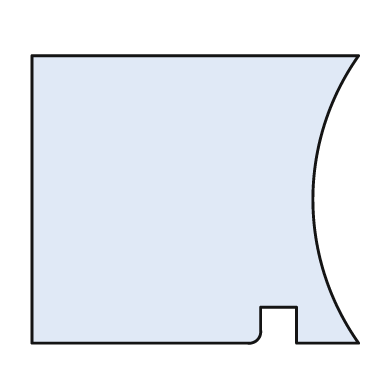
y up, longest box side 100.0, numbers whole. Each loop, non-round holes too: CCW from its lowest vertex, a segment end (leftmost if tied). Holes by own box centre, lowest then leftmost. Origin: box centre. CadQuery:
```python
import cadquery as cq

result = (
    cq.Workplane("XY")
    .moveTo(-50.0, -44.0)
    .lineTo(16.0, -44.0)
    .threePointArc((19.0, -43.0), (20.0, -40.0))
    .lineTo(20.0, -33.0)
    .lineTo(31.0, -33.0)
    .lineTo(31.0, -44.0)
    .lineTo(50.0, -44.0)
    .threePointArc((36.0, 0.0), (50.0, 44.0))
    .lineTo(-50.0, 44.0)
    .close()
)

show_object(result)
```